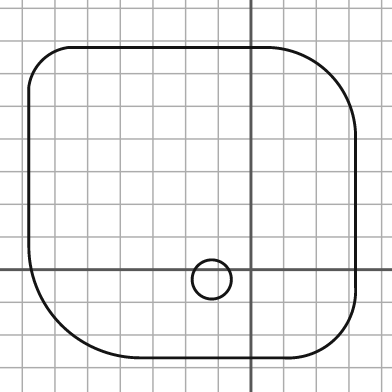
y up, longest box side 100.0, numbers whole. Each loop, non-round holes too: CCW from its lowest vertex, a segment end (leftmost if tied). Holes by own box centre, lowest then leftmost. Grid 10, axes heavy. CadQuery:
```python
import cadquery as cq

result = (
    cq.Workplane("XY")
    .moveTo(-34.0, -27.0)
    .lineTo(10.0, -27.0)
    .threePointArc((26.0, -21.0), (32.0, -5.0))
    .lineTo(32.0, 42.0)
    .threePointArc((24.0, 60.0), (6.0, 68.0))
    .lineTo(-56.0, 68.0)
    .threePointArc((-64.0, 64.0), (-68.0, 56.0))
    .lineTo(-68.0, 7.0)
    .threePointArc((-58.0, -17.0), (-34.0, -27.0))
    .close()
    .moveTo(-12.0, -3.0)
    .circle(6.0)
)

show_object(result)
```